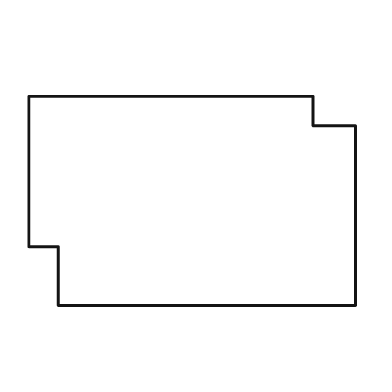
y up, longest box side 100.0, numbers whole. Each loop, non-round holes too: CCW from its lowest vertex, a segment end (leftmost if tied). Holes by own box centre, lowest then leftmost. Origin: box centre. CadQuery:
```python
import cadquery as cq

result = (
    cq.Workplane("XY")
    .moveTo(-41.0, -32.0)
    .lineTo(50.0, -32.0)
    .lineTo(50.0, 23.0)
    .lineTo(37.0, 23.0)
    .lineTo(37.0, 32.0)
    .lineTo(-50.0, 32.0)
    .lineTo(-50.0, -14.0)
    .lineTo(-41.0, -14.0)
    .close()
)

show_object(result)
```